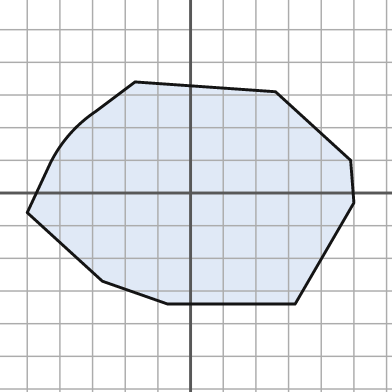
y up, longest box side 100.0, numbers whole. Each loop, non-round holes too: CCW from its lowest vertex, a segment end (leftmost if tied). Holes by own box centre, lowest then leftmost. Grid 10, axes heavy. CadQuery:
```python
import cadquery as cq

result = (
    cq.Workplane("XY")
    .moveTo(-7.0, -34.0)
    .lineTo(32.0, -34.0)
    .lineTo(50.0, -3.0)
    .lineTo(49.0, 10.0)
    .lineTo(26.0, 31.0)
    .lineTo(-17.0, 34.0)
    .lineTo(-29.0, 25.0)
    .threePointArc((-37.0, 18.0), (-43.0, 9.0))
    .lineTo(-50.0, -6.0)
    .lineTo(-27.0, -27.0)
    .close()
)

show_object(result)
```